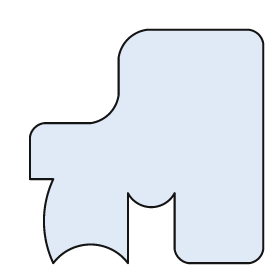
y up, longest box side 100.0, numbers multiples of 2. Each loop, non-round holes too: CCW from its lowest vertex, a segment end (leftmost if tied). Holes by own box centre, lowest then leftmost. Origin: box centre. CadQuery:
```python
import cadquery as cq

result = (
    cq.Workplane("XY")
    .moveTo(-40.0, -50.0)
    .threePointArc((-24.0, -42.0), (-8.0, -50.0))
    .lineTo(-8.0, -20.0)
    .threePointArc((2.0, -26.0), (12.0, -20.0))
    .lineTo(12.0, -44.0)
    .threePointArc((14.0, -48.0), (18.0, -50.0))
    .lineTo(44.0, -50.0)
    .threePointArc((48.0, -48.0), (50.0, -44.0))
    .lineTo(50.0, 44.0)
    .threePointArc((48.0, 48.0), (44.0, 50.0))
    .lineTo(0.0, 50.0)
    .threePointArc((-8.0, 46.0), (-12.0, 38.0))
    .lineTo(-12.0, 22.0)
    .threePointArc((-16.0, 14.0), (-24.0, 10.0))
    .lineTo(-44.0, 10.0)
    .threePointArc((-48.0, 8.0), (-50.0, 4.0))
    .lineTo(-50.0, -14.0)
    .lineTo(-40.0, -14.0)
    .threePointArc((-44.0, -32.0), (-40.0, -50.0))
    .close()
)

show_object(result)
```